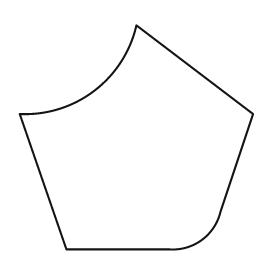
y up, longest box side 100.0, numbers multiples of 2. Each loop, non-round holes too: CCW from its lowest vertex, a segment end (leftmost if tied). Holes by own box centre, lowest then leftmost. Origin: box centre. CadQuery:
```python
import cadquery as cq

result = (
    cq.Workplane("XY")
    .moveTo(-30.0, -48.0)
    .lineTo(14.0, -48.0)
    .threePointArc((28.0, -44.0), (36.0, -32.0))
    .lineTo(50.0, 10.0)
    .lineTo(0.0, 48.0)
    .threePointArc((-18.0, 20.0), (-50.0, 10.0))
    .close()
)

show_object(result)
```